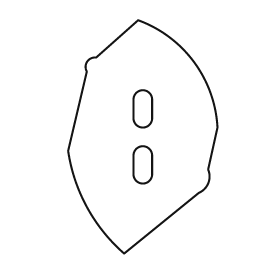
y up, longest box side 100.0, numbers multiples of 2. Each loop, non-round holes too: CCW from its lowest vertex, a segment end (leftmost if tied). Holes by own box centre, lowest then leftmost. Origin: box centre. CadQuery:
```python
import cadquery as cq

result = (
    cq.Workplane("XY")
    .moveTo(-8.0, -50.0)
    .lineTo(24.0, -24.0)
    .threePointArc((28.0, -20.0), (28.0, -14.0))
    .lineTo(32.0, 4.0)
    .threePointArc((22.0, 32.0), (-2.0, 50.0))
    .lineTo(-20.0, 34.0)
    .threePointArc((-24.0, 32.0), (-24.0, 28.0))
    .lineTo(-32.0, -6.0)
    .threePointArc((-24.0, -30.0), (-8.0, -50.0))
    .close()
    .moveTo(-4.0, -16.0)
    .threePointArc((0.0, -20.0), (4.0, -16.0))
    .lineTo(4.0, -8.0)
    .threePointArc((0.0, -4.0), (-4.0, -8.0))
    .close()
    .moveTo(-4.0, 8.0)
    .threePointArc((0.0, 4.0), (4.0, 8.0))
    .lineTo(4.0, 16.0)
    .threePointArc((0.0, 20.0), (-4.0, 16.0))
    .close()
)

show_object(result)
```